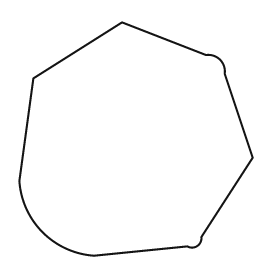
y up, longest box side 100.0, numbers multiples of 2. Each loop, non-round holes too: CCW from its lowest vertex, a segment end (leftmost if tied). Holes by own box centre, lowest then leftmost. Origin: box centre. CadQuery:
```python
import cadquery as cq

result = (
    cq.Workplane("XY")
    .moveTo(-18.0, -50.0)
    .lineTo(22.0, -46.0)
    .threePointArc((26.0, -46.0), (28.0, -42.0))
    .lineTo(50.0, -8.0)
    .lineTo(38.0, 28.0)
    .threePointArc((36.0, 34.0), (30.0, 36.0))
    .lineTo(-6.0, 50.0)
    .lineTo(-44.0, 26.0)
    .lineTo(-50.0, -18.0)
    .threePointArc((-40.0, -40.0), (-18.0, -50.0))
    .close()
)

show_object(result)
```